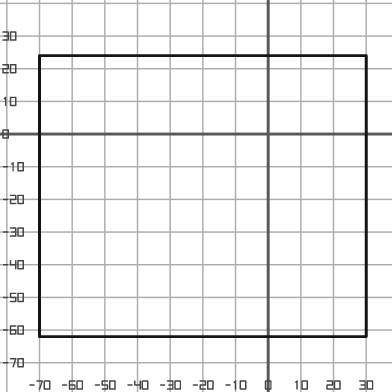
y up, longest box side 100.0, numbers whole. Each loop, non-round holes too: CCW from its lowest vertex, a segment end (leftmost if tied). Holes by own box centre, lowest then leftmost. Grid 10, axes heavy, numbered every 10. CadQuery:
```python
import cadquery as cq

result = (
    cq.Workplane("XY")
    .moveTo(-70.0, -62.0)
    .lineTo(30.0, -62.0)
    .lineTo(30.0, 24.0)
    .lineTo(-70.0, 24.0)
    .close()
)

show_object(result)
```